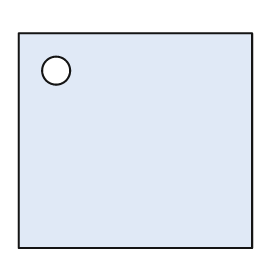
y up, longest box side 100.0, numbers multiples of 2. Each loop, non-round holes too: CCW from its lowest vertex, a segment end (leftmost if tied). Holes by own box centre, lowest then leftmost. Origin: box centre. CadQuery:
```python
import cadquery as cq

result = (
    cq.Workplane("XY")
    .moveTo(-50.0, -46.0)
    .lineTo(50.0, -46.0)
    .lineTo(50.0, 46.0)
    .lineTo(-50.0, 46.0)
    .close()
    .moveTo(-34.0, 30.0)
    .circle(6.0)
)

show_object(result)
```